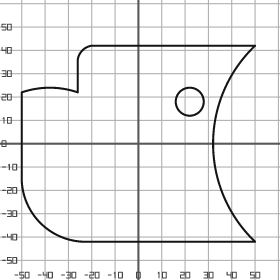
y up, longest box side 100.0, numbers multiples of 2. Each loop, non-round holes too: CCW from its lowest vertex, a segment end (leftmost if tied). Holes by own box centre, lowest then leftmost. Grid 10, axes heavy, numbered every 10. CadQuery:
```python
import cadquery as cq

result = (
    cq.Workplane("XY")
    .moveTo(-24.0, -42.0)
    .lineTo(50.0, -42.0)
    .threePointArc((32.0, 0.0), (50.0, 42.0))
    .lineTo(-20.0, 42.0)
    .threePointArc((-24.0, 40.0), (-26.0, 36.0))
    .lineTo(-26.0, 22.0)
    .threePointArc((-38.0, 24.0), (-50.0, 22.0))
    .lineTo(-50.0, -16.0)
    .threePointArc((-42.0, -34.0), (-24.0, -42.0))
    .close()
    .moveTo(22.0, 18.0)
    .circle(6.0)
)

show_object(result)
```